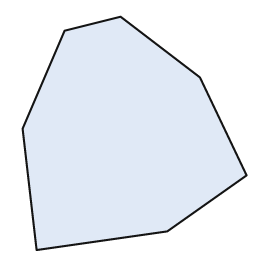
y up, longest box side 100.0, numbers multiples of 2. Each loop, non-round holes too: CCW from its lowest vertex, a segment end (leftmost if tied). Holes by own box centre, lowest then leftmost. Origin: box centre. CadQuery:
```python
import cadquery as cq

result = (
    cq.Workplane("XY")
    .moveTo(-42.0, -50.0)
    .lineTo(14.0, -42.0)
    .lineTo(48.0, -18.0)
    .lineTo(28.0, 24.0)
    .lineTo(-6.0, 50.0)
    .lineTo(-30.0, 44.0)
    .lineTo(-48.0, 2.0)
    .close()
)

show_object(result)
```